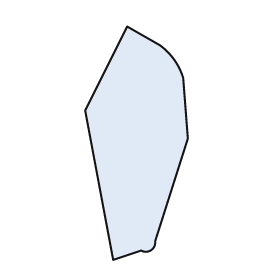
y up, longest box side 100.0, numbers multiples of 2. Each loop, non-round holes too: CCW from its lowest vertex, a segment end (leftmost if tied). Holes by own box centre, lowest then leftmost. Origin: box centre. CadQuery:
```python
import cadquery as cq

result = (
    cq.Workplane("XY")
    .moveTo(-10.0, -50.0)
    .lineTo(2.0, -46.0)
    .threePointArc((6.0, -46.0), (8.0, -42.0))
    .lineTo(22.0, 2.0)
    .lineTo(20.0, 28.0)
    .threePointArc((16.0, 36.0), (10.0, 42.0))
    .lineTo(-4.0, 50.0)
    .lineTo(-22.0, 14.0)
    .close()
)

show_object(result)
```